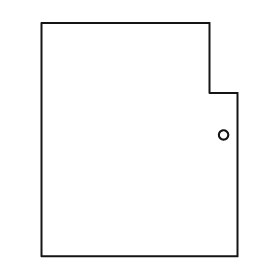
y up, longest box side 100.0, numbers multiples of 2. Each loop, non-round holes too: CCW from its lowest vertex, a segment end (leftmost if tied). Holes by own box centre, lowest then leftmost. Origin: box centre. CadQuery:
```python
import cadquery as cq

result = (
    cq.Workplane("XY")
    .moveTo(-42.0, -50.0)
    .lineTo(42.0, -50.0)
    .lineTo(42.0, 20.0)
    .lineTo(30.0, 20.0)
    .lineTo(30.0, 50.0)
    .lineTo(-42.0, 50.0)
    .close()
    .moveTo(36.0, 2.0)
    .circle(2.0)
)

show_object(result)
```